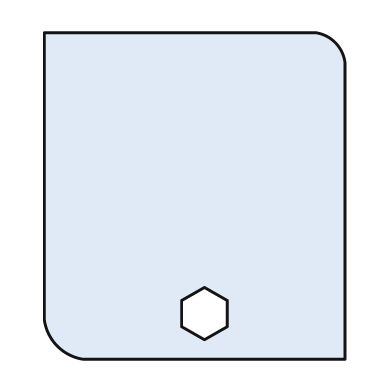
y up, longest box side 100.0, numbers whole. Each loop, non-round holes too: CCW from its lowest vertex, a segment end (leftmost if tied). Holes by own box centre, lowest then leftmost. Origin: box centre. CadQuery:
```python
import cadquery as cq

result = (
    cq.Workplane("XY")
    .moveTo(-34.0, -50.0)
    .lineTo(46.0, -50.0)
    .lineTo(46.0, 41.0)
    .threePointArc((43.0, 47.0), (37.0, 50.0))
    .lineTo(-46.0, 50.0)
    .lineTo(-46.0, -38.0)
    .threePointArc((-42.0, -46.0), (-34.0, -50.0))
    .close()
    .moveTo(3.0, -44.0)
    .lineTo(10.0, -40.0)
    .lineTo(10.0, -32.0)
    .lineTo(3.0, -28.0)
    .lineTo(-4.0, -32.0)
    .lineTo(-4.0, -40.0)
    .close()
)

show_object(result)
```